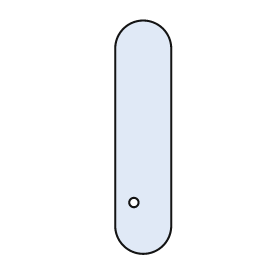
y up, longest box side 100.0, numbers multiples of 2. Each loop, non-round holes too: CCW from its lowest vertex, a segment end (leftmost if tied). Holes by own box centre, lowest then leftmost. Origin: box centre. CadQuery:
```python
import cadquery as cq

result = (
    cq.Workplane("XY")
    .moveTo(-12.0, -38.0)
    .threePointArc((0.0, -50.0), (12.0, -38.0))
    .lineTo(12.0, 38.0)
    .threePointArc((0.0, 50.0), (-12.0, 38.0))
    .close()
    .moveTo(-4.0, -28.0)
    .circle(2.0)
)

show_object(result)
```